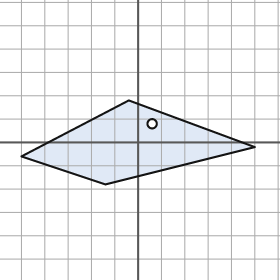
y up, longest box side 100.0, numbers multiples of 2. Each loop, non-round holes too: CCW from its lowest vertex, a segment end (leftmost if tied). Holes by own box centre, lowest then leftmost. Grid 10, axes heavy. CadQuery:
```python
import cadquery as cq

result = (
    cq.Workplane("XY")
    .moveTo(-14.0, -18.0)
    .lineTo(50.0, -2.0)
    .lineTo(-4.0, 18.0)
    .lineTo(-50.0, -6.0)
    .close()
    .moveTo(6.0, 8.0)
    .circle(2.0)
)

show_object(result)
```